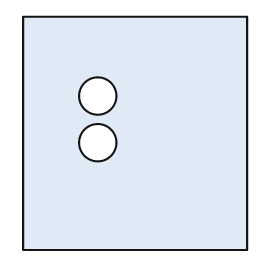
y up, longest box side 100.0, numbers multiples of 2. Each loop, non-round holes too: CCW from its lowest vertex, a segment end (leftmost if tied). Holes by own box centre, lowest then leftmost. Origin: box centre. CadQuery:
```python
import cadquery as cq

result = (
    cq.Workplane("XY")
    .moveTo(-48.0, -50.0)
    .lineTo(48.0, -50.0)
    .lineTo(48.0, 50.0)
    .lineTo(-48.0, 50.0)
    .close()
    .moveTo(-16.0, -4.0)
    .circle(8.0)
    .moveTo(-16.0, 16.0)
    .circle(8.0)
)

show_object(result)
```